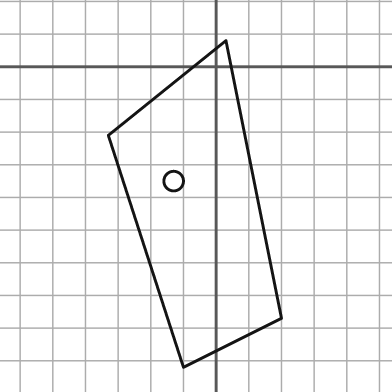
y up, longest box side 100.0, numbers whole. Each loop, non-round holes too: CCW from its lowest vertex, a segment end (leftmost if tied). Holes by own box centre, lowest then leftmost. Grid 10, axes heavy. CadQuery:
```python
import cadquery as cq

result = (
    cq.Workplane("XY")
    .moveTo(-10.0, -92.0)
    .lineTo(20.0, -77.0)
    .lineTo(3.0, 8.0)
    .lineTo(-33.0, -21.0)
    .close()
    .moveTo(-13.0, -35.0)
    .circle(3.0)
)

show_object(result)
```